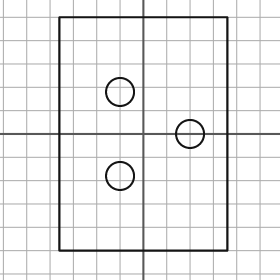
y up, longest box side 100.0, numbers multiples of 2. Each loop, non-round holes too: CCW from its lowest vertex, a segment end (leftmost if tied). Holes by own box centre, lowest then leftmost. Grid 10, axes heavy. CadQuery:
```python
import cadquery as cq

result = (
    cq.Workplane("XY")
    .moveTo(-36.0, -50.0)
    .lineTo(36.0, -50.0)
    .lineTo(36.0, 50.0)
    .lineTo(-36.0, 50.0)
    .close()
    .moveTo(-10.0, -18.0)
    .circle(6.0)
    .moveTo(20.0, 0.0)
    .circle(6.0)
    .moveTo(-10.0, 18.0)
    .circle(6.0)
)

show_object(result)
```